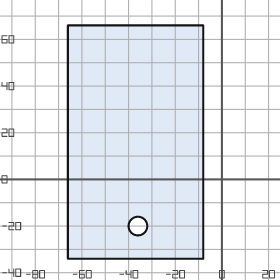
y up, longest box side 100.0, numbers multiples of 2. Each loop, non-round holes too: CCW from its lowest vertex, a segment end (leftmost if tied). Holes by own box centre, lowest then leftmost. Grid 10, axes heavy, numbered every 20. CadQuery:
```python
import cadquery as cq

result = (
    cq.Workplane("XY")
    .moveTo(-66.0, -34.0)
    .lineTo(-8.0, -34.0)
    .lineTo(-8.0, 66.0)
    .lineTo(-66.0, 66.0)
    .close()
    .moveTo(-36.0, -20.0)
    .circle(4.0)
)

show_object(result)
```